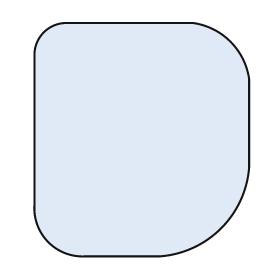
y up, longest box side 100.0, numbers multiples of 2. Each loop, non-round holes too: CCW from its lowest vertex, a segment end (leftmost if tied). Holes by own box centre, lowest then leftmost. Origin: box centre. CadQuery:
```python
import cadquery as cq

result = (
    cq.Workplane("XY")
    .moveTo(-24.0, -50.0)
    .lineTo(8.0, -50.0)
    .threePointArc((34.0, -38.0), (46.0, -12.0))
    .lineTo(46.0, 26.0)
    .threePointArc((38.0, 42.0), (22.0, 50.0))
    .lineTo(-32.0, 50.0)
    .threePointArc((-42.0, 46.0), (-46.0, 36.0))
    .lineTo(-46.0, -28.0)
    .threePointArc((-40.0, -44.0), (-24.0, -50.0))
    .close()
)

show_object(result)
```